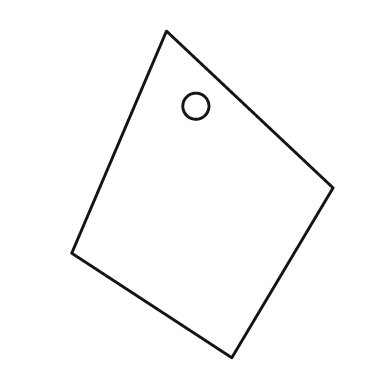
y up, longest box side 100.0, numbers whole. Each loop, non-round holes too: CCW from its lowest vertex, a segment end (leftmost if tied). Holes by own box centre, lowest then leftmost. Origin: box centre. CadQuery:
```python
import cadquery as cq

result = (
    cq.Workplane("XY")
    .moveTo(9.0, -50.0)
    .lineTo(40.0, 2.0)
    .lineTo(-11.0, 50.0)
    .lineTo(-40.0, -18.0)
    .close()
    .moveTo(-2.0, 27.0)
    .circle(4.0)
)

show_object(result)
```